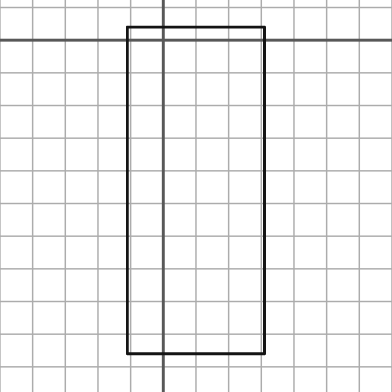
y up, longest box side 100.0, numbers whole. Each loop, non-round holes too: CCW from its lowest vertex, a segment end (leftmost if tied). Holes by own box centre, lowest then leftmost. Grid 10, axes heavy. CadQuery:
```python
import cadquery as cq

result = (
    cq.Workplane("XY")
    .moveTo(-11.0, -96.0)
    .lineTo(31.0, -96.0)
    .lineTo(31.0, 4.0)
    .lineTo(-11.0, 4.0)
    .close()
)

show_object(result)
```